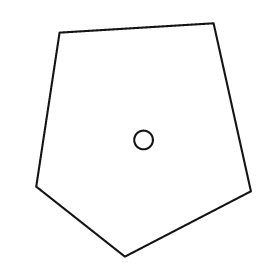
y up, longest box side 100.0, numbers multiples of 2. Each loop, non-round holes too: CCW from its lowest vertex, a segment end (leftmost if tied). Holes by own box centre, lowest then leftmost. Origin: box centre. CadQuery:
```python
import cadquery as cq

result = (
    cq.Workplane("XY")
    .moveTo(-8.0, -50.0)
    .lineTo(46.0, -22.0)
    .lineTo(30.0, 50.0)
    .lineTo(-36.0, 46.0)
    .lineTo(-46.0, -20.0)
    .close()
    .moveTo(0.0, 0.0)
    .circle(4.0)
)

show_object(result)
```